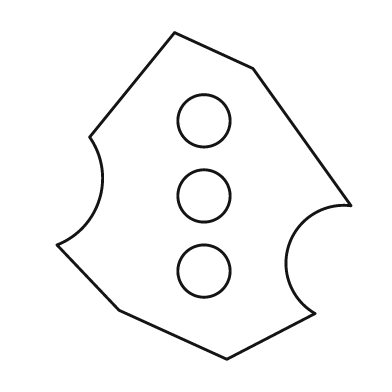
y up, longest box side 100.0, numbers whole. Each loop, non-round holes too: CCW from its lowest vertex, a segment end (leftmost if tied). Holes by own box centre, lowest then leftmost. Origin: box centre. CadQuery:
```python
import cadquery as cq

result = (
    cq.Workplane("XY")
    .moveTo(7.0, -50.0)
    .lineTo(34.0, -36.0)
    .threePointArc((26.0, -15.0), (45.0, -3.0))
    .lineTo(15.0, 39.0)
    .lineTo(-9.0, 50.0)
    .lineTo(-35.0, 18.0)
    .threePointArc((-32.0, -1.0), (-45.0, -15.0))
    .lineTo(-26.0, -35.0)
    .close()
    .moveTo(0.0, -23.0)
    .circle(8.0)
    .moveTo(0.0, 0.0)
    .circle(8.0)
    .moveTo(0.0, 23.0)
    .circle(8.0)
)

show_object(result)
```